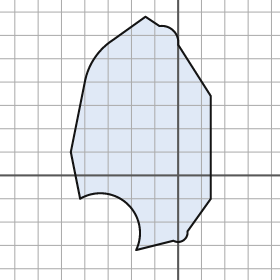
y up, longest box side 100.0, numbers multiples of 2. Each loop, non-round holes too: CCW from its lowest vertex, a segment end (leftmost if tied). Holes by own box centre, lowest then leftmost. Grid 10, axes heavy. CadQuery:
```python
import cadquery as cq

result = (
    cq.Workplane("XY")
    .moveTo(-18.0, -32.0)
    .lineTo(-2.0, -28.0)
    .threePointArc((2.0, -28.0), (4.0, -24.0))
    .lineTo(14.0, -10.0)
    .lineTo(14.0, 34.0)
    .lineTo(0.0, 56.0)
    .threePointArc((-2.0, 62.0), (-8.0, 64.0))
    .lineTo(-14.0, 68.0)
    .lineTo(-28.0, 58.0)
    .threePointArc((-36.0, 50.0), (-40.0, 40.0))
    .lineTo(-46.0, 10.0)
    .lineTo(-42.0, -10.0)
    .threePointArc((-22.0, -12.0), (-18.0, -32.0))
    .close()
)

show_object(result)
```